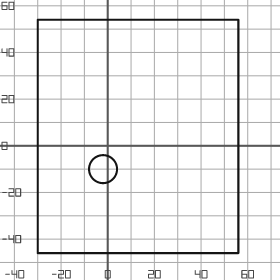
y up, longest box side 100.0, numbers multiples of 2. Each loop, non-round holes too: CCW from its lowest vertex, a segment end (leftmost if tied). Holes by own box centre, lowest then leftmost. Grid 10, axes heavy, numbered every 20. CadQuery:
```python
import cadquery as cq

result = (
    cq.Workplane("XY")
    .moveTo(-30.0, -46.0)
    .lineTo(56.0, -46.0)
    .lineTo(56.0, 54.0)
    .lineTo(-30.0, 54.0)
    .close()
    .moveTo(-2.0, -10.0)
    .circle(6.0)
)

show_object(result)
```